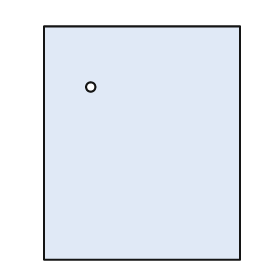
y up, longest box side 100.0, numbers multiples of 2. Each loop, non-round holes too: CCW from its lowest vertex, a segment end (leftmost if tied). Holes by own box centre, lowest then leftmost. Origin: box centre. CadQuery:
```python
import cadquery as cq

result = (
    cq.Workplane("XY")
    .moveTo(-42.0, -50.0)
    .lineTo(42.0, -50.0)
    .lineTo(42.0, 50.0)
    .lineTo(-42.0, 50.0)
    .close()
    .moveTo(-22.0, 24.0)
    .circle(2.0)
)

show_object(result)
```